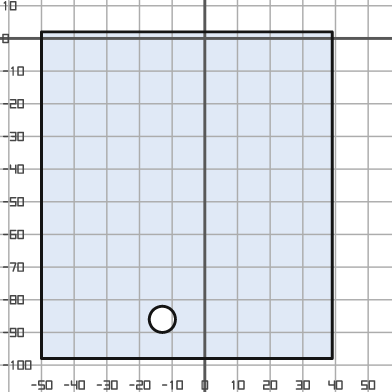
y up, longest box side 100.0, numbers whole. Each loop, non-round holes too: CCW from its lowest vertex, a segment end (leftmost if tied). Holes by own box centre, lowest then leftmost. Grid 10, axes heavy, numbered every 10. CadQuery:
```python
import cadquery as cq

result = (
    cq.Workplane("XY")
    .moveTo(-50.0, -98.0)
    .lineTo(39.0, -98.0)
    .lineTo(39.0, 2.0)
    .lineTo(-50.0, 2.0)
    .close()
    .moveTo(-13.0, -86.0)
    .circle(4.0)
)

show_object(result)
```